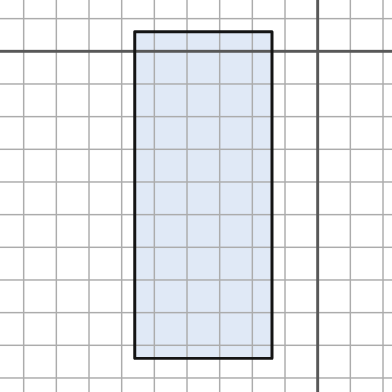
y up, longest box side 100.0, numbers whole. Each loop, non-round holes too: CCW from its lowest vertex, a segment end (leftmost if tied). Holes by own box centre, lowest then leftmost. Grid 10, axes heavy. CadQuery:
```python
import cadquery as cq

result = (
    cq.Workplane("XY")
    .moveTo(-56.0, -94.0)
    .lineTo(-14.0, -94.0)
    .lineTo(-14.0, 6.0)
    .lineTo(-56.0, 6.0)
    .close()
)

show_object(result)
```